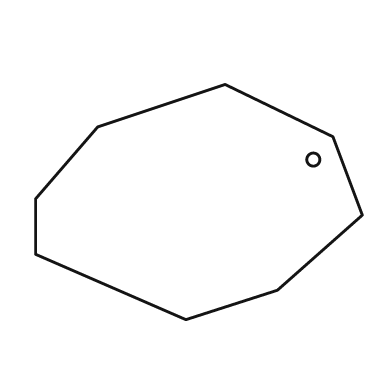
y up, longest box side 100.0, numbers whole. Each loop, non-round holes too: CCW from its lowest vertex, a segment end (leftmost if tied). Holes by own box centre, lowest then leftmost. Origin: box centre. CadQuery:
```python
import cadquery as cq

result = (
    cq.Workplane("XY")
    .moveTo(-4.0, -36.0)
    .lineTo(24.0, -27.0)
    .lineTo(50.0, -4.0)
    .lineTo(41.0, 20.0)
    .lineTo(8.0, 36.0)
    .lineTo(-31.0, 23.0)
    .lineTo(-50.0, 1.0)
    .lineTo(-50.0, -16.0)
    .close()
    .moveTo(35.0, 13.0)
    .circle(2.0)
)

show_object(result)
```